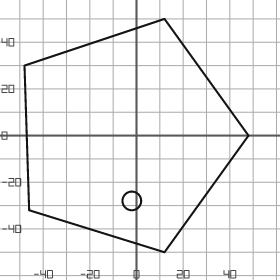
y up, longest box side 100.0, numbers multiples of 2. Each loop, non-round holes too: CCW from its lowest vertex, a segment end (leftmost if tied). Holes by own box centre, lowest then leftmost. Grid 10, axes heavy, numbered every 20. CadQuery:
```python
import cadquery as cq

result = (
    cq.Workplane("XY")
    .moveTo(12.0, -50.0)
    .lineTo(48.0, 0.0)
    .lineTo(12.0, 50.0)
    .lineTo(-48.0, 30.0)
    .lineTo(-46.0, -32.0)
    .close()
    .moveTo(-2.0, -28.0)
    .circle(4.0)
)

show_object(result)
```